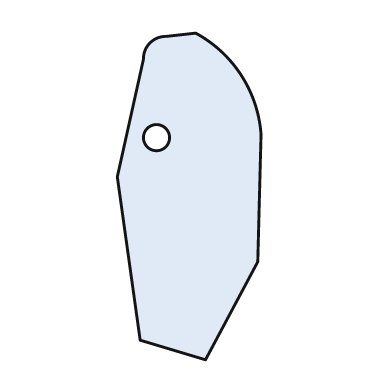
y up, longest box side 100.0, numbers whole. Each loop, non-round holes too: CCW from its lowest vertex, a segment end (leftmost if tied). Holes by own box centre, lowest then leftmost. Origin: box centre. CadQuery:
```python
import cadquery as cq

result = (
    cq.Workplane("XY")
    .moveTo(5.0, -50.0)
    .lineTo(21.0, -20.0)
    .lineTo(22.0, 19.0)
    .threePointArc((16.0, 37.0), (2.0, 50.0))
    .lineTo(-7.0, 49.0)
    .threePointArc((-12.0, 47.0), (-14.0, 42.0))
    .lineTo(-22.0, 6.0)
    .lineTo(-15.0, -44.0)
    .close()
    .moveTo(-10.0, 18.0)
    .circle(4.0)
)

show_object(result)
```